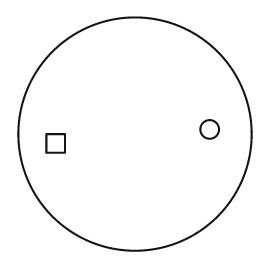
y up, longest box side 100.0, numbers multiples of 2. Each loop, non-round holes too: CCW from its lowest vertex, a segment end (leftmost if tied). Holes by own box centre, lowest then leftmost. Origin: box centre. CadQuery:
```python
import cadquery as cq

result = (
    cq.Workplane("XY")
    .moveTo(0.0, 0.0)
    .circle(50.0)
    .moveTo(-38.0, -8.0)
    .lineTo(-30.0, -8.0)
    .lineTo(-30.0, 0.0)
    .lineTo(-38.0, 0.0)
    .close()
    .moveTo(32.0, 2.0)
    .circle(4.0)
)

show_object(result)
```